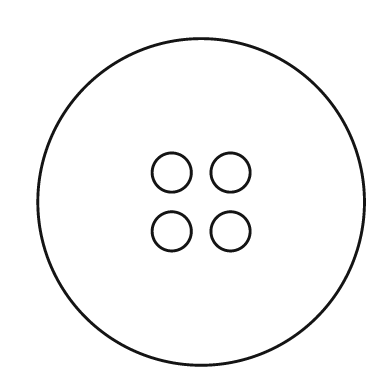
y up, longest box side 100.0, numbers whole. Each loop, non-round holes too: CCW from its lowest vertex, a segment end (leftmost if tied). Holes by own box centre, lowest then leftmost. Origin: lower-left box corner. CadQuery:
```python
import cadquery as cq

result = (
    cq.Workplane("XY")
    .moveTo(50.0, 50.0)
    .circle(50.0)
    .moveTo(41.0, 41.0)
    .circle(6.0)
    .moveTo(59.0, 41.0)
    .circle(6.0)
    .moveTo(41.0, 59.0)
    .circle(6.0)
    .moveTo(59.0, 59.0)
    .circle(6.0)
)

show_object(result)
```